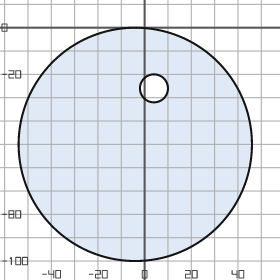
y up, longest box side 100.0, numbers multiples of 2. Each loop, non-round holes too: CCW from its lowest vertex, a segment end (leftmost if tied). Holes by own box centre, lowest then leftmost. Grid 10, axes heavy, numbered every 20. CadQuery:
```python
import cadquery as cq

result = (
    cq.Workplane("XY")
    .moveTo(-4.0, -50.0)
    .circle(50.0)
    .moveTo(4.0, -26.0)
    .circle(6.0)
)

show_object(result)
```